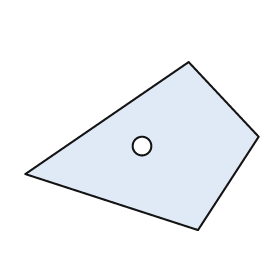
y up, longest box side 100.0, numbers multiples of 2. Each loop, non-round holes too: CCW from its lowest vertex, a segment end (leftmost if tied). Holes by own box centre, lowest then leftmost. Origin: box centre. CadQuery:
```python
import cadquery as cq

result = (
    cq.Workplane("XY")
    .moveTo(24.0, -36.0)
    .lineTo(50.0, 4.0)
    .lineTo(20.0, 36.0)
    .lineTo(-50.0, -12.0)
    .close()
    .moveTo(0.0, 0.0)
    .circle(4.0)
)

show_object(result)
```